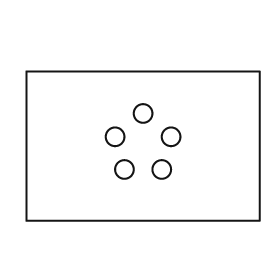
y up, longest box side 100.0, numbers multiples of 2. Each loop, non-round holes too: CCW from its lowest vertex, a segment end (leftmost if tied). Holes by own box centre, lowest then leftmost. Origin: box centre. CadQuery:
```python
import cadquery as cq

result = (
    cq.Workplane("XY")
    .moveTo(-50.0, -32.0)
    .lineTo(50.0, -32.0)
    .lineTo(50.0, 32.0)
    .lineTo(-50.0, 32.0)
    .close()
    .moveTo(-8.0, -10.0)
    .circle(4.0)
    .moveTo(8.0, -10.0)
    .circle(4.0)
    .moveTo(-12.0, 4.0)
    .circle(4.0)
    .moveTo(12.0, 4.0)
    .circle(4.0)
    .moveTo(0.0, 14.0)
    .circle(4.0)
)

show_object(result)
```